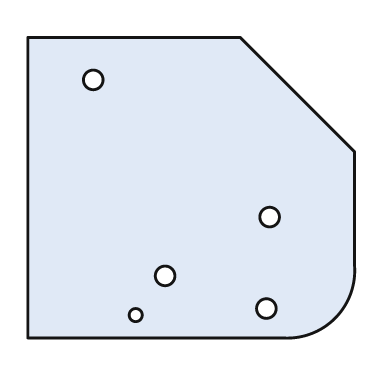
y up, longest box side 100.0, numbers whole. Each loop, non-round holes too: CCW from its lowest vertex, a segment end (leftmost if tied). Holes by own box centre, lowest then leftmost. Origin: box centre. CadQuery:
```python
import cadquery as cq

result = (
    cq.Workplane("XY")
    .moveTo(-50.0, -46.0)
    .lineTo(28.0, -46.0)
    .threePointArc((44.0, -40.0), (50.0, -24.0))
    .lineTo(50.0, 11.0)
    .lineTo(15.0, 46.0)
    .lineTo(-50.0, 46.0)
    .close()
    .moveTo(-17.0, -39.0)
    .circle(2.0)
    .moveTo(23.0, -37.0)
    .circle(3.0)
    .moveTo(-8.0, -27.0)
    .circle(3.0)
    .moveTo(24.0, -9.0)
    .circle(3.0)
    .moveTo(-30.0, 33.0)
    .circle(3.0)
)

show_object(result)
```